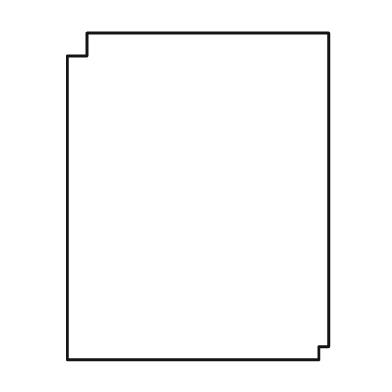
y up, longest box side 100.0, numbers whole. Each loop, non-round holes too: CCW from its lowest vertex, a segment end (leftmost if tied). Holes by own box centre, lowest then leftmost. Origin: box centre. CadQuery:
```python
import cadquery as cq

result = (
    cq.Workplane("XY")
    .moveTo(-40.0, -50.0)
    .lineTo(37.0, -50.0)
    .lineTo(37.0, -46.0)
    .lineTo(40.0, -46.0)
    .lineTo(40.0, 50.0)
    .lineTo(-34.0, 50.0)
    .lineTo(-34.0, 43.0)
    .lineTo(-40.0, 43.0)
    .close()
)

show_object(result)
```